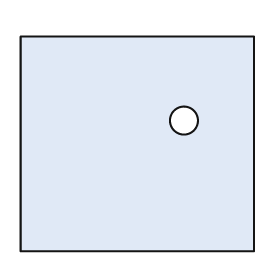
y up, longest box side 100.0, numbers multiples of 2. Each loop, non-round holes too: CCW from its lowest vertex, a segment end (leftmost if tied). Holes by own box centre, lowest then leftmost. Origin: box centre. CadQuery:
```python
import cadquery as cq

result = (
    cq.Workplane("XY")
    .moveTo(-50.0, -46.0)
    .lineTo(50.0, -46.0)
    .lineTo(50.0, 46.0)
    .lineTo(-50.0, 46.0)
    .close()
    .moveTo(20.0, 10.0)
    .circle(6.0)
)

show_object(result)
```